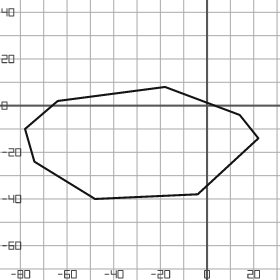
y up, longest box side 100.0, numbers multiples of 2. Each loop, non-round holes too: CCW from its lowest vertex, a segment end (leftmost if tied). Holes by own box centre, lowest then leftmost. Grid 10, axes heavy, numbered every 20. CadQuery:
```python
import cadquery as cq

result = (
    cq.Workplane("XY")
    .moveTo(-48.0, -40.0)
    .lineTo(-4.0, -38.0)
    .lineTo(22.0, -14.0)
    .lineTo(14.0, -4.0)
    .lineTo(-18.0, 8.0)
    .lineTo(-64.0, 2.0)
    .lineTo(-78.0, -10.0)
    .lineTo(-74.0, -24.0)
    .close()
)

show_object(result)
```